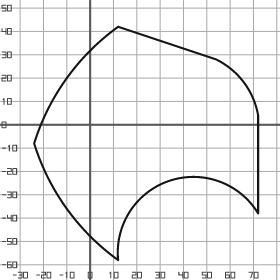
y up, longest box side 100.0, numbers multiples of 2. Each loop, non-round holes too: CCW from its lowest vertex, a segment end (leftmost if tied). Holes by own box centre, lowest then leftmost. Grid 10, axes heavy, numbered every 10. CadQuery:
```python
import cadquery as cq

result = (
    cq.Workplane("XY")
    .moveTo(12.0, -58.0)
    .threePointArc((34.0, -24.0), (72.0, -38.0))
    .lineTo(72.0, 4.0)
    .threePointArc((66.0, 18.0), (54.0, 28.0))
    .lineTo(12.0, 42.0)
    .threePointArc((-10.0, 20.0), (-24.0, -8.0))
    .threePointArc((-10.0, -36.0), (12.0, -58.0))
    .close()
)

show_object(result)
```